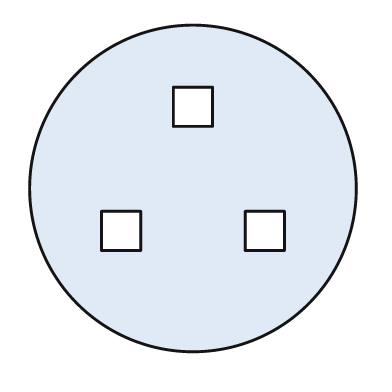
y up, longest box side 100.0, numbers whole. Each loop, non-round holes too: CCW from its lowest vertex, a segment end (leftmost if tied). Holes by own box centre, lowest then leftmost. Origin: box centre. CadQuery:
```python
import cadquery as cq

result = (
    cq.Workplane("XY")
    .moveTo(0.0, 0.0)
    .circle(50.0)
    .moveTo(-28.0, -19.0)
    .lineTo(-16.0, -19.0)
    .lineTo(-16.0, -7.0)
    .lineTo(-28.0, -7.0)
    .close()
    .moveTo(16.0, -19.0)
    .lineTo(28.0, -19.0)
    .lineTo(28.0, -7.0)
    .lineTo(16.0, -7.0)
    .close()
    .moveTo(-6.0, 19.0)
    .lineTo(6.0, 19.0)
    .lineTo(6.0, 31.0)
    .lineTo(-6.0, 31.0)
    .close()
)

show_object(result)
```